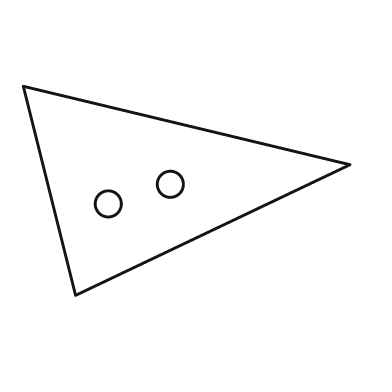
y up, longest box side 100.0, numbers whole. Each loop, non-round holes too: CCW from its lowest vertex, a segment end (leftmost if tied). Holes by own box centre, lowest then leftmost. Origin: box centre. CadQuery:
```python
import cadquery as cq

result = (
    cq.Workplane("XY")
    .moveTo(-34.0, -32.0)
    .lineTo(50.0, 8.0)
    .lineTo(-50.0, 32.0)
    .close()
    .moveTo(-24.0, -4.0)
    .circle(4.0)
    .moveTo(-5.0, 2.0)
    .circle(4.0)
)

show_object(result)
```